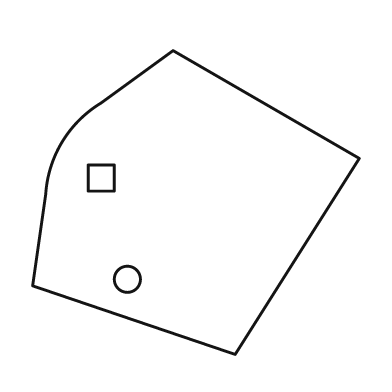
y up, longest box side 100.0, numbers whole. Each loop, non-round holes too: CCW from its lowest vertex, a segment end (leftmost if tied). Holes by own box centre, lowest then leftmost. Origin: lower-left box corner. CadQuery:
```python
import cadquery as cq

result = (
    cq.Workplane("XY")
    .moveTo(62.0, 0.0)
    .lineTo(100.0, 60.0)
    .lineTo(43.0, 93.0)
    .lineTo(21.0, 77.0)
    .threePointArc((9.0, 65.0), (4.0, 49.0))
    .lineTo(0.0, 21.0)
    .close()
    .moveTo(29.0, 23.0)
    .circle(4.0)
    .moveTo(17.0, 50.0)
    .lineTo(25.0, 50.0)
    .lineTo(25.0, 58.0)
    .lineTo(17.0, 58.0)
    .close()
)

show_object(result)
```